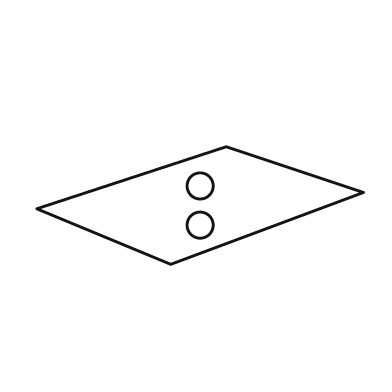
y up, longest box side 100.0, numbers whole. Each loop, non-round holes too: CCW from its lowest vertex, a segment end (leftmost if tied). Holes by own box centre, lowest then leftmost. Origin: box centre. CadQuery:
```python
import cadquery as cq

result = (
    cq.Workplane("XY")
    .moveTo(-9.0, -18.0)
    .lineTo(50.0, 4.0)
    .lineTo(8.0, 18.0)
    .lineTo(-50.0, -1.0)
    .close()
    .moveTo(0.0, -6.0)
    .circle(4.0)
    .moveTo(0.0, 6.0)
    .circle(4.0)
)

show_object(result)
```